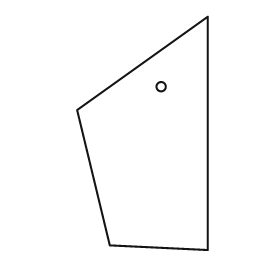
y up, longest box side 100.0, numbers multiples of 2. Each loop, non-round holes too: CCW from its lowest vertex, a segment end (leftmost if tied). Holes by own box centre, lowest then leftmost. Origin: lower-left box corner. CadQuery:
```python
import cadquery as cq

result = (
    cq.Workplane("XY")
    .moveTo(56.0, 0.0)
    .lineTo(56.0, 100.0)
    .lineTo(0.0, 60.0)
    .lineTo(14.0, 2.0)
    .close()
    .moveTo(36.0, 70.0)
    .circle(2.0)
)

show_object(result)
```